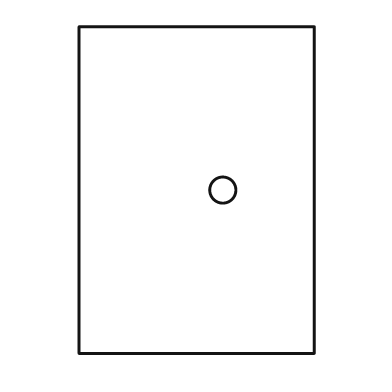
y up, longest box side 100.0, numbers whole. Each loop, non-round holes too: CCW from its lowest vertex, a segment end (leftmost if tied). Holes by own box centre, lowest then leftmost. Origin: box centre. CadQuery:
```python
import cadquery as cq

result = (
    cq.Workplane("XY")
    .moveTo(-36.0, -50.0)
    .lineTo(36.0, -50.0)
    .lineTo(36.0, 50.0)
    .lineTo(-36.0, 50.0)
    .close()
    .moveTo(8.0, 0.0)
    .circle(4.0)
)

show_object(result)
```